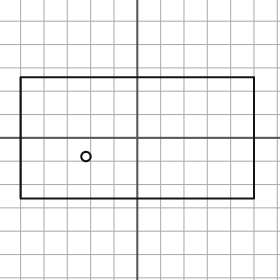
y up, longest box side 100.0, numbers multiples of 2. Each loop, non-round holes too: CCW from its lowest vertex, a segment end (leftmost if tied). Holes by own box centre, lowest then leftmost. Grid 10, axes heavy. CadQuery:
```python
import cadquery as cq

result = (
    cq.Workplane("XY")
    .moveTo(-50.0, -26.0)
    .lineTo(50.0, -26.0)
    .lineTo(50.0, 26.0)
    .lineTo(-50.0, 26.0)
    .close()
    .moveTo(-22.0, -8.0)
    .circle(2.0)
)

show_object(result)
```